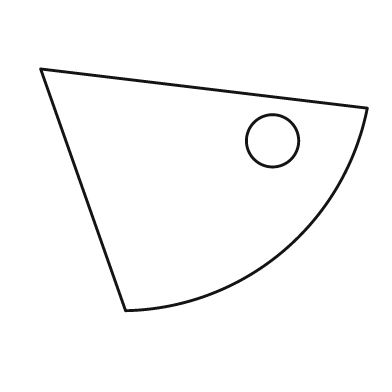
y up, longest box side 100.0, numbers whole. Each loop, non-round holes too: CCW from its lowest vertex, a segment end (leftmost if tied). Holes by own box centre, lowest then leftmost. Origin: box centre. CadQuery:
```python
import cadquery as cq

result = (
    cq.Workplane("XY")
    .moveTo(-24.0, -37.0)
    .threePointArc((24.0, -19.0), (50.0, 25.0))
    .lineTo(-50.0, 37.0)
    .close()
    .moveTo(21.0, 15.0)
    .circle(8.0)
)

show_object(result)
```